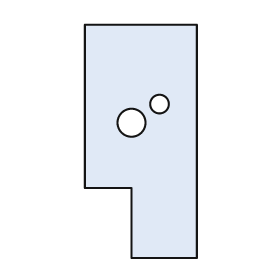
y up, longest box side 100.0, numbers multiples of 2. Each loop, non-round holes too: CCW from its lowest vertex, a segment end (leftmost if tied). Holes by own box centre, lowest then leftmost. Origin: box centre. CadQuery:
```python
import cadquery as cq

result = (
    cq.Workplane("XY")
    .moveTo(-4.0, -50.0)
    .lineTo(24.0, -50.0)
    .lineTo(24.0, 50.0)
    .lineTo(-24.0, 50.0)
    .lineTo(-24.0, -20.0)
    .lineTo(-4.0, -20.0)
    .close()
    .moveTo(-4.0, 8.0)
    .circle(6.0)
    .moveTo(8.0, 16.0)
    .circle(4.0)
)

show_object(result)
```